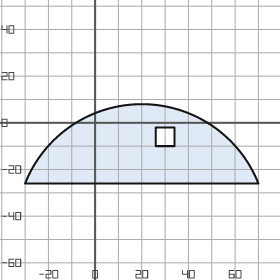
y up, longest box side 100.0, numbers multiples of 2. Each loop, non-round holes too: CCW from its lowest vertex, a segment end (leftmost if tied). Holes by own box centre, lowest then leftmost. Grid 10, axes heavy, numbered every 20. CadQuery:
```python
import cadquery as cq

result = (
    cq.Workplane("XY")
    .moveTo(-30.0, -26.0)
    .lineTo(70.0, -26.0)
    .threePointArc((20.0, 8.0), (-30.0, -26.0))
    .close()
    .moveTo(26.0, -10.0)
    .lineTo(34.0, -10.0)
    .lineTo(34.0, -2.0)
    .lineTo(26.0, -2.0)
    .close()
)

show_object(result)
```